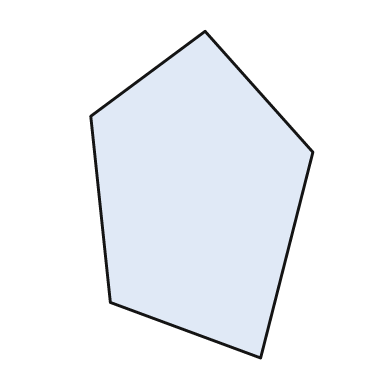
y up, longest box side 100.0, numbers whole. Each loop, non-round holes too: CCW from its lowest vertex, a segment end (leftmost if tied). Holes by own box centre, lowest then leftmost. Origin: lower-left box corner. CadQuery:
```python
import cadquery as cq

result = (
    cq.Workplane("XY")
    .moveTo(52.0, 0.0)
    .lineTo(68.0, 63.0)
    .lineTo(35.0, 100.0)
    .lineTo(0.0, 74.0)
    .lineTo(6.0, 17.0)
    .close()
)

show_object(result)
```